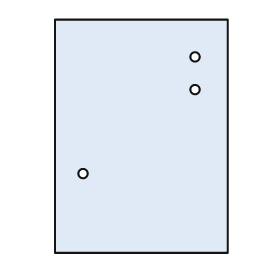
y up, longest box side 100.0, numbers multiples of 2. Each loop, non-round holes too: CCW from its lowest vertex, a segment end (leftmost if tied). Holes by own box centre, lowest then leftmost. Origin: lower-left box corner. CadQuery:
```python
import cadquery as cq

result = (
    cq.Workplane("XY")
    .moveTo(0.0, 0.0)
    .lineTo(74.0, 0.0)
    .lineTo(74.0, 100.0)
    .lineTo(0.0, 100.0)
    .close()
    .moveTo(12.0, 34.0)
    .circle(2.0)
    .moveTo(60.0, 70.0)
    .circle(2.0)
    .moveTo(60.0, 84.0)
    .circle(2.0)
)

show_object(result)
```